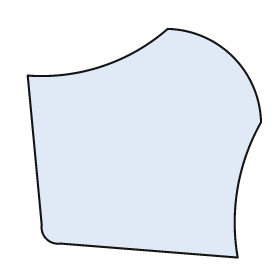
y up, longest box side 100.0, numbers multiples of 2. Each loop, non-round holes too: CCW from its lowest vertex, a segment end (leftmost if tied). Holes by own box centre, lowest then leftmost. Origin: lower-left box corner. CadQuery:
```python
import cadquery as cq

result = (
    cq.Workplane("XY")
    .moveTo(90.0, 0.0)
    .threePointArc((90.0, 30.0), (100.0, 58.0))
    .threePointArc((88.0, 86.0), (60.0, 98.0))
    .threePointArc((32.0, 82.0), (0.0, 78.0))
    .lineTo(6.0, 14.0)
    .threePointArc((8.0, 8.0), (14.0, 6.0))
    .close()
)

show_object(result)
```